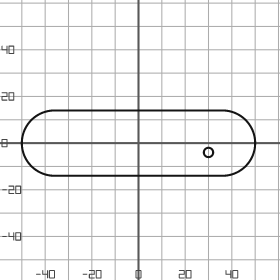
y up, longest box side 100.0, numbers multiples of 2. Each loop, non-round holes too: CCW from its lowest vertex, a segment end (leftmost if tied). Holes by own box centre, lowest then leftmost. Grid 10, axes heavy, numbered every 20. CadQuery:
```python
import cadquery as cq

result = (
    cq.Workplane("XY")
    .moveTo(-36.0, -14.0)
    .lineTo(36.0, -14.0)
    .threePointArc((50.0, 0.0), (36.0, 14.0))
    .lineTo(-36.0, 14.0)
    .threePointArc((-50.0, 0.0), (-36.0, -14.0))
    .close()
    .moveTo(30.0, -4.0)
    .circle(2.0)
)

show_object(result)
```